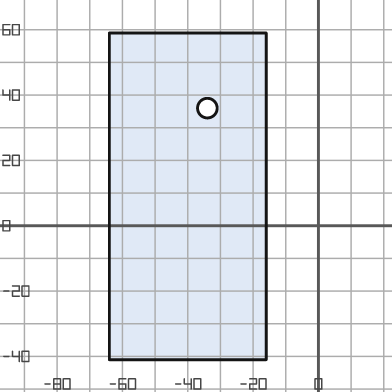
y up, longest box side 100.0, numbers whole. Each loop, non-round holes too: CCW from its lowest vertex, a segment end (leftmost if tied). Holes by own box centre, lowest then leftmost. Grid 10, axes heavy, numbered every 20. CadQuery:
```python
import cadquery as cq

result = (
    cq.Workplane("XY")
    .moveTo(-64.0, -41.0)
    .lineTo(-16.0, -41.0)
    .lineTo(-16.0, 59.0)
    .lineTo(-64.0, 59.0)
    .close()
    .moveTo(-34.0, 36.0)
    .circle(3.0)
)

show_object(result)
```